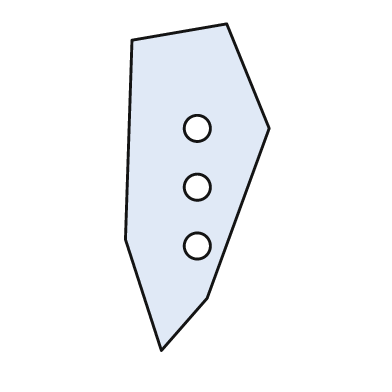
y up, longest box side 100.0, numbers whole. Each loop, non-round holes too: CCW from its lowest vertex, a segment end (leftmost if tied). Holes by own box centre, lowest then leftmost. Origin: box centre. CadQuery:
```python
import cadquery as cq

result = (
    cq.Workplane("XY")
    .moveTo(-11.0, -50.0)
    .lineTo(3.0, -34.0)
    .lineTo(22.0, 18.0)
    .lineTo(9.0, 50.0)
    .lineTo(-20.0, 45.0)
    .lineTo(-22.0, -16.0)
    .close()
    .moveTo(0.0, -18.0)
    .circle(4.0)
    .moveTo(0.0, 0.0)
    .circle(4.0)
    .moveTo(0.0, 18.0)
    .circle(4.0)
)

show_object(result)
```